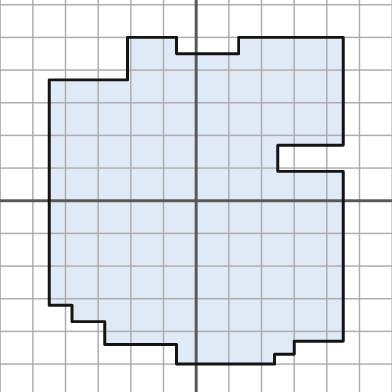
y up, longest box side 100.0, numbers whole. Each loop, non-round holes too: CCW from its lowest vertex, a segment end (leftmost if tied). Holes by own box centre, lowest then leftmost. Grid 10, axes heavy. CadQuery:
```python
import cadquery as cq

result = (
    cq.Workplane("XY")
    .moveTo(-6.0, -50.0)
    .lineTo(24.0, -50.0)
    .lineTo(24.0, -47.0)
    .lineTo(30.0, -47.0)
    .lineTo(30.0, -43.0)
    .lineTo(45.0, -43.0)
    .lineTo(45.0, 9.0)
    .lineTo(25.0, 9.0)
    .lineTo(25.0, 17.0)
    .lineTo(45.0, 17.0)
    .lineTo(45.0, 50.0)
    .lineTo(13.0, 50.0)
    .lineTo(13.0, 45.0)
    .lineTo(-6.0, 45.0)
    .lineTo(-6.0, 50.0)
    .lineTo(-21.0, 50.0)
    .lineTo(-21.0, 37.0)
    .lineTo(-45.0, 37.0)
    .lineTo(-45.0, -32.0)
    .lineTo(-38.0, -32.0)
    .lineTo(-38.0, -37.0)
    .lineTo(-28.0, -37.0)
    .lineTo(-28.0, -44.0)
    .lineTo(-6.0, -44.0)
    .close()
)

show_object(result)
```